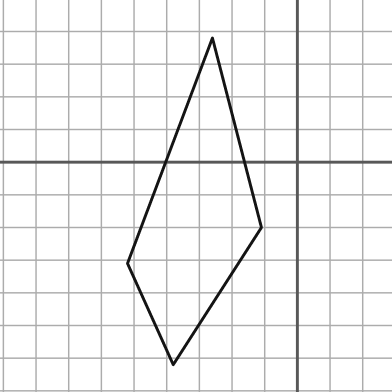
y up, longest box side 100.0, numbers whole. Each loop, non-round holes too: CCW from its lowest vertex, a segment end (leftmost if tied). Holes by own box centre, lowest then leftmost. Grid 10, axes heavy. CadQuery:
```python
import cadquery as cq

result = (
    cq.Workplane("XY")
    .moveTo(-38.0, -62.0)
    .lineTo(-11.0, -20.0)
    .lineTo(-26.0, 38.0)
    .lineTo(-52.0, -31.0)
    .close()
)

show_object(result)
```